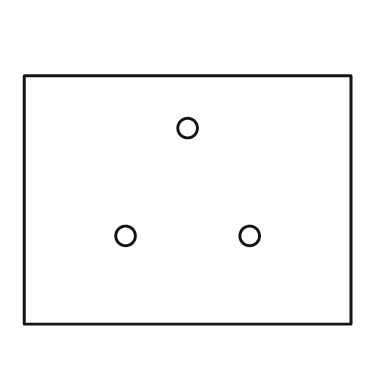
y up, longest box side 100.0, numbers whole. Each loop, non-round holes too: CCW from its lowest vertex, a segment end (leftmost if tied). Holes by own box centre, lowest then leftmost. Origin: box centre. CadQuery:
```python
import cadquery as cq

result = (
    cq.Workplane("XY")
    .moveTo(-50.0, -38.0)
    .lineTo(50.0, -38.0)
    .lineTo(50.0, 38.0)
    .lineTo(-50.0, 38.0)
    .close()
    .moveTo(-19.0, -11.0)
    .circle(3.0)
    .moveTo(19.0, -11.0)
    .circle(3.0)
    .moveTo(0.0, 22.0)
    .circle(3.0)
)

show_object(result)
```